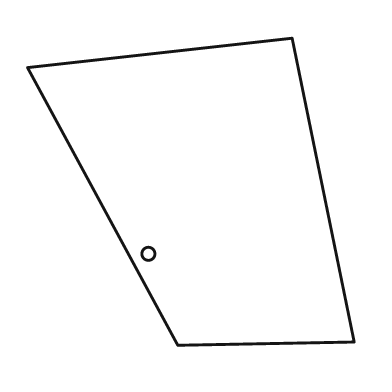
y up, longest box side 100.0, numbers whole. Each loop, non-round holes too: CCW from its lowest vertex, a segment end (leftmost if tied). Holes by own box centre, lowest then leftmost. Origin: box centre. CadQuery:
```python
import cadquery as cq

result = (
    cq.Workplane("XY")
    .moveTo(-4.0, -47.0)
    .lineTo(50.0, -46.0)
    .lineTo(31.0, 47.0)
    .lineTo(-50.0, 38.0)
    .close()
    .moveTo(-13.0, -19.0)
    .circle(2.0)
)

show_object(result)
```